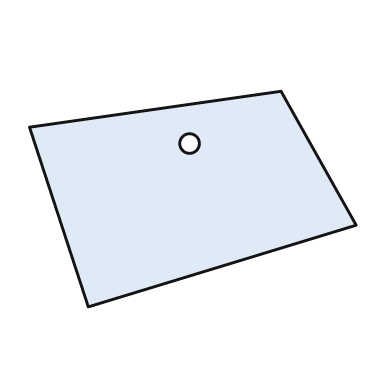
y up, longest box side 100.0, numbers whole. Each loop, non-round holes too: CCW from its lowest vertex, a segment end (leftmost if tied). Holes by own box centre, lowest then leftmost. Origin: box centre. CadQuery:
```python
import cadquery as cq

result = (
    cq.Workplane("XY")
    .moveTo(-32.0, -33.0)
    .lineTo(50.0, -8.0)
    .lineTo(27.0, 33.0)
    .lineTo(-50.0, 22.0)
    .close()
    .moveTo(-1.0, 17.0)
    .circle(3.0)
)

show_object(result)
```